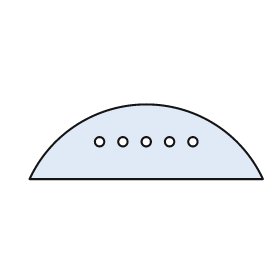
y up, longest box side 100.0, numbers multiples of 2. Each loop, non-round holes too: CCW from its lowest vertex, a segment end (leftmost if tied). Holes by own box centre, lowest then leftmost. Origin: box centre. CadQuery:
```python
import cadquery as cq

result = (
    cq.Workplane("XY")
    .moveTo(-50.0, -16.0)
    .lineTo(50.0, -16.0)
    .threePointArc((0.0, 16.0), (-50.0, -16.0))
    .close()
    .moveTo(-20.0, 0.0)
    .circle(2.0)
    .moveTo(-10.0, 0.0)
    .circle(2.0)
    .moveTo(0.0, 0.0)
    .circle(2.0)
    .moveTo(10.0, 0.0)
    .circle(2.0)
    .moveTo(20.0, 0.0)
    .circle(2.0)
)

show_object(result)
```